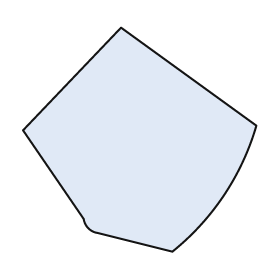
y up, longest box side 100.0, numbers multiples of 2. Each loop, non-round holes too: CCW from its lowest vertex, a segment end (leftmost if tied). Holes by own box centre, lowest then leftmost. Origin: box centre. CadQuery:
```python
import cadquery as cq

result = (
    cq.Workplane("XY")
    .moveTo(14.0, -48.0)
    .threePointArc((36.0, -24.0), (50.0, 6.0))
    .lineTo(-8.0, 48.0)
    .lineTo(-50.0, 4.0)
    .lineTo(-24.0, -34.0)
    .threePointArc((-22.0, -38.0), (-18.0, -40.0))
    .close()
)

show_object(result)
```